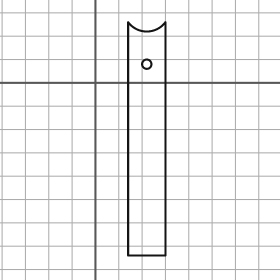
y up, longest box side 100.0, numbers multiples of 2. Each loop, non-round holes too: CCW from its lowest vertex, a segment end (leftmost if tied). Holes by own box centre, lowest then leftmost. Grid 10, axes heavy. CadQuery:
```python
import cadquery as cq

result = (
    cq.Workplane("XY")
    .moveTo(14.0, -74.0)
    .lineTo(30.0, -74.0)
    .lineTo(30.0, 26.0)
    .threePointArc((22.0, 22.0), (14.0, 26.0))
    .close()
    .moveTo(22.0, 8.0)
    .circle(2.0)
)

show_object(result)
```